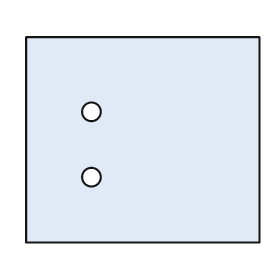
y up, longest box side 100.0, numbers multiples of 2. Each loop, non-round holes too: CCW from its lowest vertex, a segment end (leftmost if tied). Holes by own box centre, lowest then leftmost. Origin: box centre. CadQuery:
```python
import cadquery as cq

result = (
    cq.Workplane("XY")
    .moveTo(-50.0, -44.0)
    .lineTo(50.0, -44.0)
    .lineTo(50.0, 44.0)
    .lineTo(-50.0, 44.0)
    .close()
    .moveTo(-22.0, -16.0)
    .circle(4.0)
    .moveTo(-22.0, 12.0)
    .circle(4.0)
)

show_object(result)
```